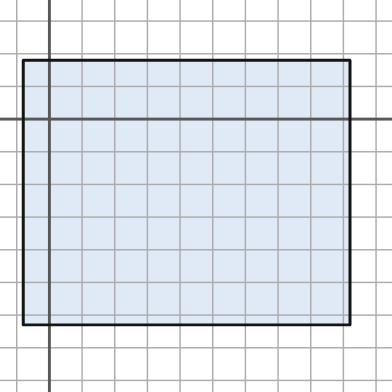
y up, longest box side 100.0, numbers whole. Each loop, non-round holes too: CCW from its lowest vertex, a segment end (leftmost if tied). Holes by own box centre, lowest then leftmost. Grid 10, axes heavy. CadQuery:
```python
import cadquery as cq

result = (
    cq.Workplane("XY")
    .moveTo(-8.0, -63.0)
    .lineTo(92.0, -63.0)
    .lineTo(92.0, 18.0)
    .lineTo(-8.0, 18.0)
    .close()
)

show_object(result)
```